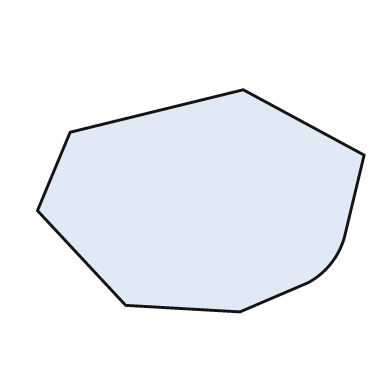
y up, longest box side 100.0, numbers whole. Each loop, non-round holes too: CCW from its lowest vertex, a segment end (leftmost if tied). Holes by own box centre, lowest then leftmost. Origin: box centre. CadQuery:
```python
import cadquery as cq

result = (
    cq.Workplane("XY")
    .moveTo(12.0, -34.0)
    .lineTo(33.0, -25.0)
    .threePointArc((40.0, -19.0), (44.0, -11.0))
    .lineTo(50.0, 14.0)
    .lineTo(13.0, 34.0)
    .lineTo(-40.0, 21.0)
    .lineTo(-50.0, -3.0)
    .lineTo(-23.0, -32.0)
    .close()
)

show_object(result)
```